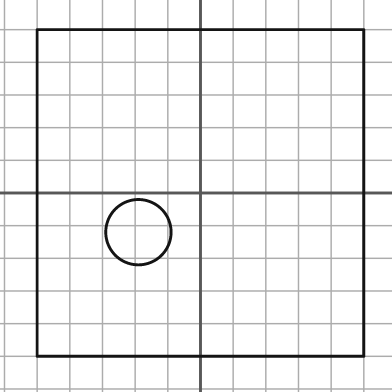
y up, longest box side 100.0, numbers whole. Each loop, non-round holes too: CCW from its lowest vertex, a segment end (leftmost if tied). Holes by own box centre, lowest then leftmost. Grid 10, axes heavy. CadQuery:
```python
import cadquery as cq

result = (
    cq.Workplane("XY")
    .moveTo(-50.0, -50.0)
    .lineTo(50.0, -50.0)
    .lineTo(50.0, 50.0)
    .lineTo(-50.0, 50.0)
    .close()
    .moveTo(-19.0, -12.0)
    .circle(10.0)
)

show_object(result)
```